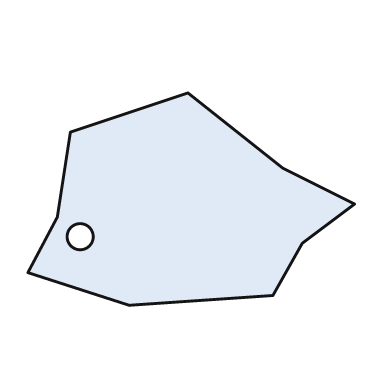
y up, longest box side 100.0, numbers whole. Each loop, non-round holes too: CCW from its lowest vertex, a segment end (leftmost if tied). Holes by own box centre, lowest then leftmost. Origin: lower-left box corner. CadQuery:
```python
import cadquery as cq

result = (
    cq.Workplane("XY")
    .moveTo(31.0, 0.0)
    .lineTo(75.0, 3.0)
    .lineTo(84.0, 19.0)
    .lineTo(100.0, 31.0)
    .lineTo(78.0, 42.0)
    .lineTo(49.0, 65.0)
    .lineTo(13.0, 53.0)
    .lineTo(9.0, 27.0)
    .lineTo(0.0, 10.0)
    .close()
    .moveTo(16.0, 21.0)
    .circle(4.0)
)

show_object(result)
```